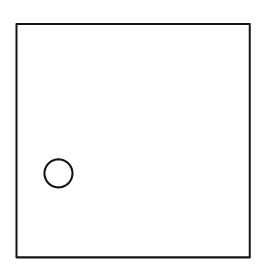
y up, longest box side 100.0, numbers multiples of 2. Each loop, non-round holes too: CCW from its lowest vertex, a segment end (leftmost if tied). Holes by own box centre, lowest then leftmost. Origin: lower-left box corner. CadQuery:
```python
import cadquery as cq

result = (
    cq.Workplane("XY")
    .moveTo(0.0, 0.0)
    .lineTo(100.0, 0.0)
    .lineTo(100.0, 100.0)
    .lineTo(0.0, 100.0)
    .close()
    .moveTo(18.0, 36.0)
    .circle(6.0)
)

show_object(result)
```